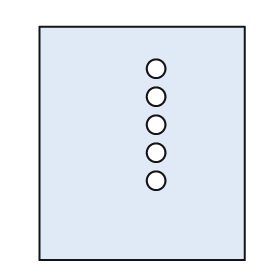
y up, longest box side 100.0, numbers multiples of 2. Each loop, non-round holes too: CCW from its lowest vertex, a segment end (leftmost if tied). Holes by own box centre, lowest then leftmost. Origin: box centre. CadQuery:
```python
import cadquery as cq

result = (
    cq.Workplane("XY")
    .moveTo(-44.0, -50.0)
    .lineTo(44.0, -50.0)
    .lineTo(44.0, 50.0)
    .lineTo(-44.0, 50.0)
    .close()
    .moveTo(6.0, -16.0)
    .circle(4.0)
    .moveTo(6.0, -4.0)
    .circle(4.0)
    .moveTo(6.0, 8.0)
    .circle(4.0)
    .moveTo(6.0, 20.0)
    .circle(4.0)
    .moveTo(6.0, 32.0)
    .circle(4.0)
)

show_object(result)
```